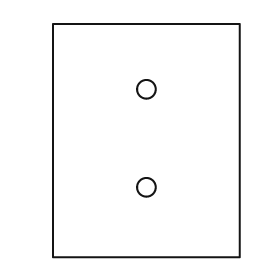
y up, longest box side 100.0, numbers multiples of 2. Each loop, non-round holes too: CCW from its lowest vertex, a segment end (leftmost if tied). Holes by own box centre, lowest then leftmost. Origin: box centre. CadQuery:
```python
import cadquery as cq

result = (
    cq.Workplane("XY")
    .moveTo(-40.0, -50.0)
    .lineTo(40.0, -50.0)
    .lineTo(40.0, 50.0)
    .lineTo(-40.0, 50.0)
    .close()
    .moveTo(0.0, -20.0)
    .circle(4.0)
    .moveTo(0.0, 22.0)
    .circle(4.0)
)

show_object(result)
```